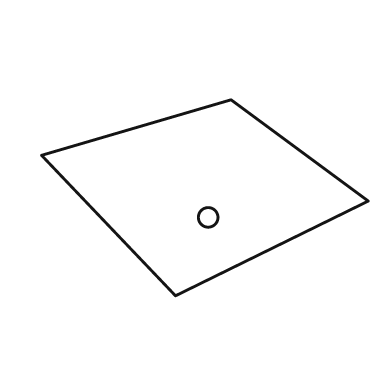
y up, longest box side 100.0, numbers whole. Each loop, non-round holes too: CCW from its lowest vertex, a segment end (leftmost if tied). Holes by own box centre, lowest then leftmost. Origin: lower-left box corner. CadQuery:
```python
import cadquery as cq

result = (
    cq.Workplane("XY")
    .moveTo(41.0, 0.0)
    .lineTo(100.0, 29.0)
    .lineTo(58.0, 60.0)
    .lineTo(0.0, 43.0)
    .close()
    .moveTo(51.0, 24.0)
    .circle(3.0)
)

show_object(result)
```